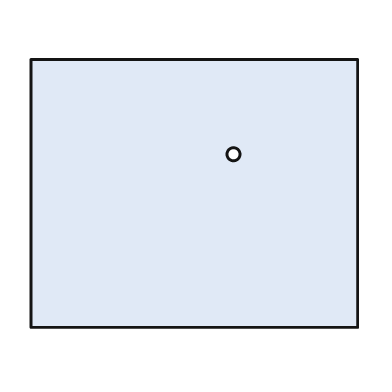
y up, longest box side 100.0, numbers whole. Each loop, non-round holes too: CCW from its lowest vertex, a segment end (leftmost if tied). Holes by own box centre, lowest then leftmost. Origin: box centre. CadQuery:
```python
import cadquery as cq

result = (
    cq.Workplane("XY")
    .moveTo(-50.0, -41.0)
    .lineTo(50.0, -41.0)
    .lineTo(50.0, 41.0)
    .lineTo(-50.0, 41.0)
    .close()
    .moveTo(12.0, 12.0)
    .circle(2.0)
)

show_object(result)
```